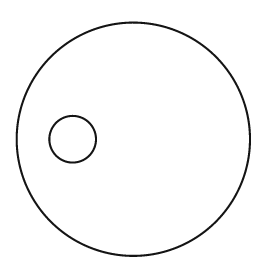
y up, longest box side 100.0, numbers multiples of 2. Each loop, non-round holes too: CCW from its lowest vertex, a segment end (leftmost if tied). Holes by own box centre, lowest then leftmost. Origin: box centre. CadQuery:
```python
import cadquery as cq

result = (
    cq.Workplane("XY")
    .moveTo(0.0, 0.0)
    .circle(50.0)
    .moveTo(-26.0, 0.0)
    .circle(10.0)
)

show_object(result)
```